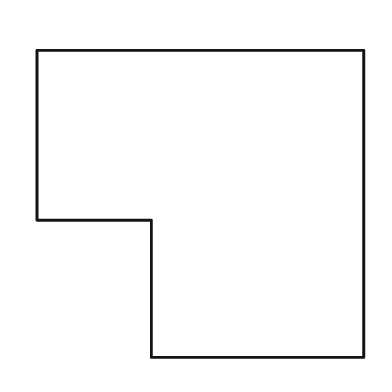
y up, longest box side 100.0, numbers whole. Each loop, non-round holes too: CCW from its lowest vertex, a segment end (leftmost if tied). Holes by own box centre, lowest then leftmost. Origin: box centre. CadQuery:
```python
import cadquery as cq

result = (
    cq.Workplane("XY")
    .moveTo(-15.0, -47.0)
    .lineTo(50.0, -47.0)
    .lineTo(50.0, 47.0)
    .lineTo(-50.0, 47.0)
    .lineTo(-50.0, -5.0)
    .lineTo(-15.0, -5.0)
    .close()
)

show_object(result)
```